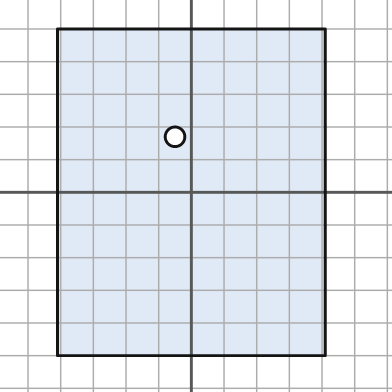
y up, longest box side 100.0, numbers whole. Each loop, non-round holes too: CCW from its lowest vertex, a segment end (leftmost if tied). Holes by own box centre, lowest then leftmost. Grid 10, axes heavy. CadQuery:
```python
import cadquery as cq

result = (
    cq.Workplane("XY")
    .moveTo(-41.0, -50.0)
    .lineTo(41.0, -50.0)
    .lineTo(41.0, 50.0)
    .lineTo(-41.0, 50.0)
    .close()
    .moveTo(-5.0, 17.0)
    .circle(3.0)
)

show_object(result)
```